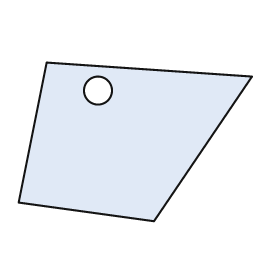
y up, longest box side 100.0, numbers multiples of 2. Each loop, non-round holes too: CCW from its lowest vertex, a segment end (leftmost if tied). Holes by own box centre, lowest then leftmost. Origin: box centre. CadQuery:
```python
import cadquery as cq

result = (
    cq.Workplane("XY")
    .moveTo(8.0, -34.0)
    .lineTo(50.0, 28.0)
    .lineTo(-38.0, 34.0)
    .lineTo(-50.0, -26.0)
    .close()
    .moveTo(-16.0, 22.0)
    .circle(6.0)
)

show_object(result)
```